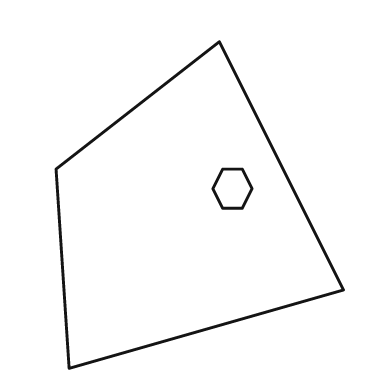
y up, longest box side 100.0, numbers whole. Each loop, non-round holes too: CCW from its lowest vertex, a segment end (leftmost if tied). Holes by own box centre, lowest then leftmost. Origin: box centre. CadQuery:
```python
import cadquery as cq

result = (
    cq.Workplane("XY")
    .moveTo(-40.0, -50.0)
    .lineTo(44.0, -26.0)
    .lineTo(6.0, 50.0)
    .lineTo(-44.0, 11.0)
    .close()
    .moveTo(7.0, -1.0)
    .lineTo(13.0, -1.0)
    .lineTo(16.0, 5.0)
    .lineTo(13.0, 11.0)
    .lineTo(7.0, 11.0)
    .lineTo(4.0, 5.0)
    .close()
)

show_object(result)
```